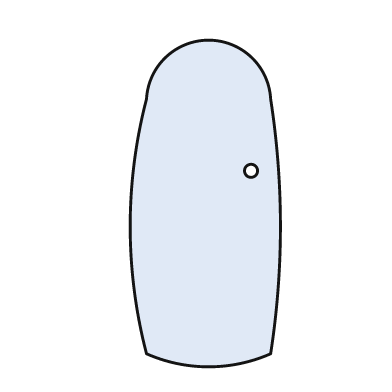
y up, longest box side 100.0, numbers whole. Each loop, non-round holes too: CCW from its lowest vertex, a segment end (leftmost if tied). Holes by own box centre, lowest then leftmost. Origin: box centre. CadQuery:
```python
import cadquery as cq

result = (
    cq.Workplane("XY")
    .moveTo(-18.0, -46.0)
    .threePointArc((1.0, -50.0), (20.0, -46.0))
    .threePointArc((23.0, -7.0), (20.0, 32.0))
    .threePointArc((1.0, 50.0), (-18.0, 32.0))
    .threePointArc((-23.0, -7.0), (-18.0, -46.0))
    .close()
    .moveTo(14.0, 10.0)
    .circle(2.0)
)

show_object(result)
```